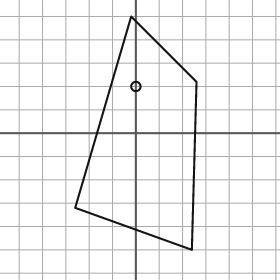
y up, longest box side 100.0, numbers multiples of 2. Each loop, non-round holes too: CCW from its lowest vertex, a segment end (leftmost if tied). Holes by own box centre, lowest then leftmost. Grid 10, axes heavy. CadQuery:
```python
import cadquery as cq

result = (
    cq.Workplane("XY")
    .moveTo(24.0, -50.0)
    .lineTo(26.0, 22.0)
    .lineTo(-2.0, 50.0)
    .lineTo(-26.0, -32.0)
    .close()
    .moveTo(0.0, 20.0)
    .circle(2.0)
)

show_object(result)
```